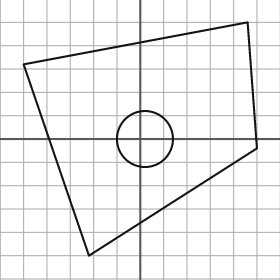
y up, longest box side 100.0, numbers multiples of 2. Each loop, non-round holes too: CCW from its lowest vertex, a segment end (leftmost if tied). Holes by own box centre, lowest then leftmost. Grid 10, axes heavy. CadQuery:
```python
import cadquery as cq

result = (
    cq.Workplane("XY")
    .moveTo(-22.0, -50.0)
    .lineTo(50.0, -4.0)
    .lineTo(46.0, 50.0)
    .lineTo(-50.0, 32.0)
    .close()
    .moveTo(2.0, 0.0)
    .circle(12.0)
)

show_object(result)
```